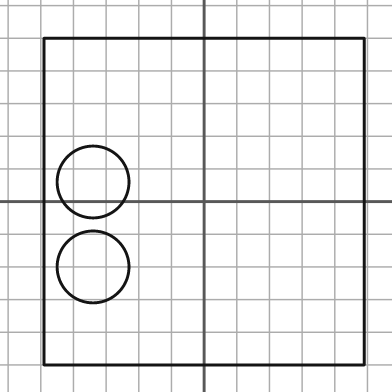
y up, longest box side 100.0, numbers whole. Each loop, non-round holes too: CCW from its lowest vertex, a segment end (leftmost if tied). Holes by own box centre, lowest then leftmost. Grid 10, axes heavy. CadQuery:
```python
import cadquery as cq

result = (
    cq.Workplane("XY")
    .moveTo(-49.0, -50.0)
    .lineTo(49.0, -50.0)
    .lineTo(49.0, 50.0)
    .lineTo(-49.0, 50.0)
    .close()
    .moveTo(-34.0, -20.0)
    .circle(11.0)
    .moveTo(-34.0, 6.0)
    .circle(11.0)
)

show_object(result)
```